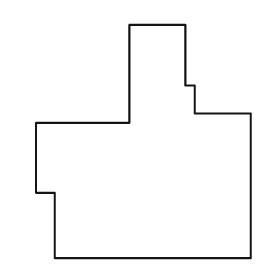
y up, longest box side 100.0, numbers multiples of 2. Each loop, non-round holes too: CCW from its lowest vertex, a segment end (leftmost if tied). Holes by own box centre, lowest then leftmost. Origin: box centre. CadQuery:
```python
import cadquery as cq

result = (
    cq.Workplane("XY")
    .moveTo(-38.0, -50.0)
    .lineTo(46.0, -50.0)
    .lineTo(46.0, 12.0)
    .lineTo(22.0, 12.0)
    .lineTo(22.0, 24.0)
    .lineTo(18.0, 24.0)
    .lineTo(18.0, 50.0)
    .lineTo(-6.0, 50.0)
    .lineTo(-6.0, 8.0)
    .lineTo(-46.0, 8.0)
    .lineTo(-46.0, -22.0)
    .lineTo(-38.0, -22.0)
    .close()
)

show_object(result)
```